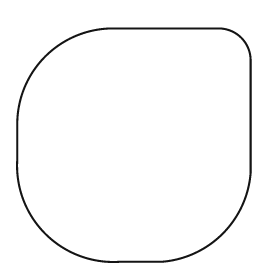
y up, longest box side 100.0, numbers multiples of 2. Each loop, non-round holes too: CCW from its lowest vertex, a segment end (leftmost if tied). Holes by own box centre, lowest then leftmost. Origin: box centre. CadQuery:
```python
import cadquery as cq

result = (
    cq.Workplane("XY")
    .moveTo(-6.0, -50.0)
    .lineTo(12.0, -50.0)
    .threePointArc((38.0, -38.0), (50.0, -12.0))
    .lineTo(50.0, 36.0)
    .threePointArc((46.0, 46.0), (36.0, 50.0))
    .lineTo(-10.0, 50.0)
    .threePointArc((-38.0, 38.0), (-50.0, 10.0))
    .lineTo(-50.0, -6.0)
    .threePointArc((-38.0, -38.0), (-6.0, -50.0))
    .close()
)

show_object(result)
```